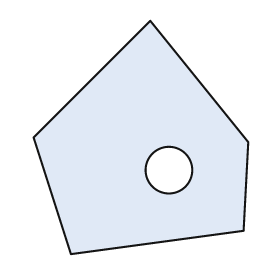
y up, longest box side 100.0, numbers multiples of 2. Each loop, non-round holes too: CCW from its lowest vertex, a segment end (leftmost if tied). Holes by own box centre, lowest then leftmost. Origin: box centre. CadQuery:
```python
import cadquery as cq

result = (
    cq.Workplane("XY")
    .moveTo(-30.0, -50.0)
    .lineTo(44.0, -40.0)
    .lineTo(46.0, -2.0)
    .lineTo(4.0, 50.0)
    .lineTo(-46.0, 0.0)
    .close()
    .moveTo(12.0, -14.0)
    .circle(10.0)
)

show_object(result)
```